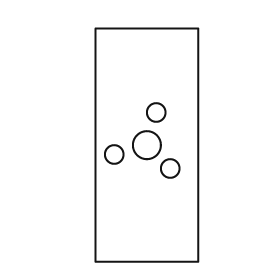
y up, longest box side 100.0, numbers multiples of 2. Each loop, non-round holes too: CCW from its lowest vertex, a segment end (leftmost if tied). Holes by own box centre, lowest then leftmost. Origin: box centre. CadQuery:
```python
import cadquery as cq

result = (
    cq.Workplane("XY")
    .moveTo(-22.0, -50.0)
    .lineTo(22.0, -50.0)
    .lineTo(22.0, 50.0)
    .lineTo(-22.0, 50.0)
    .close()
    .moveTo(10.0, -10.0)
    .circle(4.0)
    .moveTo(-14.0, -4.0)
    .circle(4.0)
    .moveTo(0.0, 0.0)
    .circle(6.0)
    .moveTo(4.0, 14.0)
    .circle(4.0)
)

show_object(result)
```